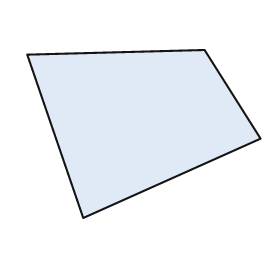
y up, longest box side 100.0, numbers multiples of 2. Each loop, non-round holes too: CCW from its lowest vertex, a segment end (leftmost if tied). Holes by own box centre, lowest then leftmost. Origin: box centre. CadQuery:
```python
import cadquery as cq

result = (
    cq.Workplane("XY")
    .moveTo(-26.0, -36.0)
    .lineTo(50.0, -2.0)
    .lineTo(26.0, 36.0)
    .lineTo(-50.0, 34.0)
    .close()
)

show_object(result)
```